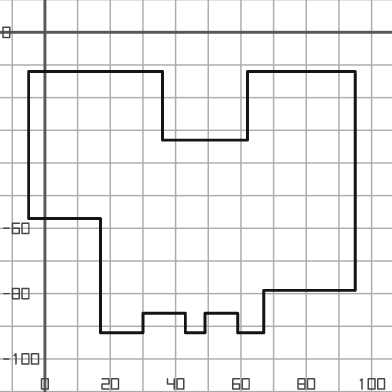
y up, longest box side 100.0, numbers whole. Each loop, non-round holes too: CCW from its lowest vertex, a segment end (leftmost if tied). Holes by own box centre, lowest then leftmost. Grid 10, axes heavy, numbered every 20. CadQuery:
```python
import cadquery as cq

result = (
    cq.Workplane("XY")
    .moveTo(17.0, -92.0)
    .lineTo(30.0, -92.0)
    .lineTo(30.0, -86.0)
    .lineTo(43.0, -86.0)
    .lineTo(43.0, -92.0)
    .lineTo(49.0, -92.0)
    .lineTo(49.0, -86.0)
    .lineTo(59.0, -86.0)
    .lineTo(59.0, -92.0)
    .lineTo(67.0, -92.0)
    .lineTo(67.0, -79.0)
    .lineTo(95.0, -79.0)
    .lineTo(95.0, -12.0)
    .lineTo(62.0, -12.0)
    .lineTo(62.0, -33.0)
    .lineTo(36.0, -33.0)
    .lineTo(36.0, -12.0)
    .lineTo(-5.0, -12.0)
    .lineTo(-5.0, -57.0)
    .lineTo(17.0, -57.0)
    .close()
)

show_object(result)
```